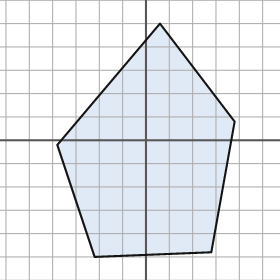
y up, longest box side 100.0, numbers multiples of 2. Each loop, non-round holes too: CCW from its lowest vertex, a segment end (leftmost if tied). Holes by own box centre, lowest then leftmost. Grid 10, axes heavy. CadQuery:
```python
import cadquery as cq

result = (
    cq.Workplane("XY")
    .moveTo(-22.0, -50.0)
    .lineTo(28.0, -48.0)
    .lineTo(38.0, 8.0)
    .lineTo(6.0, 50.0)
    .lineTo(-38.0, -2.0)
    .close()
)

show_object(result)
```